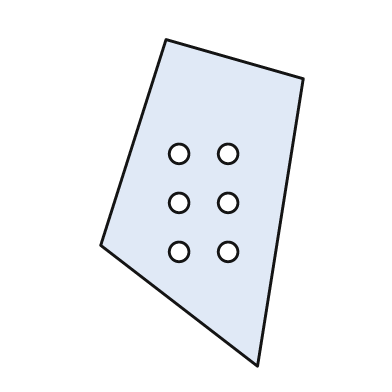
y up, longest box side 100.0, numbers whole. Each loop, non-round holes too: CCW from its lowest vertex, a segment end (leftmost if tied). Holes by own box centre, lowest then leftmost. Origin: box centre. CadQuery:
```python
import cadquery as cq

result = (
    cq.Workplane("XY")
    .moveTo(17.0, -50.0)
    .lineTo(31.0, 38.0)
    .lineTo(-11.0, 50.0)
    .lineTo(-31.0, -13.0)
    .close()
    .moveTo(-7.0, -15.0)
    .circle(3.0)
    .moveTo(8.0, -15.0)
    .circle(3.0)
    .moveTo(-7.0, 0.0)
    .circle(3.0)
    .moveTo(8.0, 0.0)
    .circle(3.0)
    .moveTo(-7.0, 15.0)
    .circle(3.0)
    .moveTo(8.0, 15.0)
    .circle(3.0)
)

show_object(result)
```